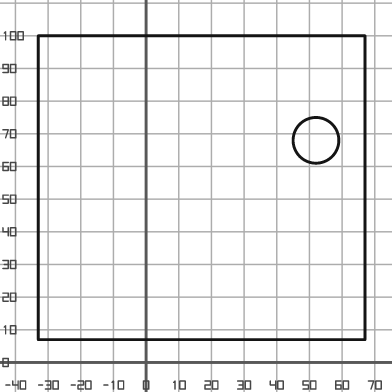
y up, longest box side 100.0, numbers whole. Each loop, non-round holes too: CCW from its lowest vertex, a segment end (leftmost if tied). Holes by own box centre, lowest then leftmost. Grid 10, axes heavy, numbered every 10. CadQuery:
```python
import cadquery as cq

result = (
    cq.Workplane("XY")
    .moveTo(-33.0, 7.0)
    .lineTo(67.0, 7.0)
    .lineTo(67.0, 100.0)
    .lineTo(-33.0, 100.0)
    .close()
    .moveTo(52.0, 68.0)
    .circle(7.0)
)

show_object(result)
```